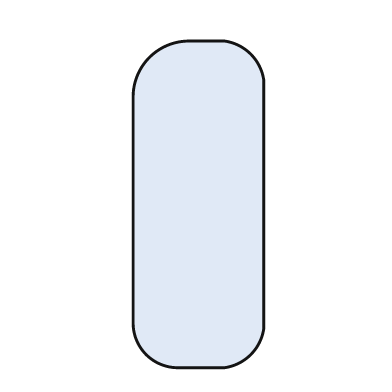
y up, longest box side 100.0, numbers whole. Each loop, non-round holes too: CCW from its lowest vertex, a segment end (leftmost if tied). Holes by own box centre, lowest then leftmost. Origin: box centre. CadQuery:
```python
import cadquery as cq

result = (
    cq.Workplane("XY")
    .moveTo(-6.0, -50.0)
    .lineTo(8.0, -50.0)
    .threePointArc((16.0, -46.0), (20.0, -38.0))
    .lineTo(20.0, 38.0)
    .threePointArc((16.0, 46.0), (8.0, 50.0))
    .lineTo(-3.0, 50.0)
    .threePointArc((-15.0, 45.0), (-20.0, 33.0))
    .lineTo(-20.0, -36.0)
    .threePointArc((-16.0, -46.0), (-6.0, -50.0))
    .close()
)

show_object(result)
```